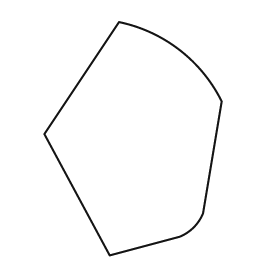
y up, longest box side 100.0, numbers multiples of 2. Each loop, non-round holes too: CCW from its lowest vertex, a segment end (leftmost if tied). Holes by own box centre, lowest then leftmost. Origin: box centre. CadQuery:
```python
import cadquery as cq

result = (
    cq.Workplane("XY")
    .moveTo(-10.0, -50.0)
    .lineTo(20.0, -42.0)
    .threePointArc((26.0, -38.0), (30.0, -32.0))
    .lineTo(38.0, 16.0)
    .threePointArc((20.0, 38.0), (-6.0, 50.0))
    .lineTo(-38.0, 2.0)
    .close()
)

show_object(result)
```